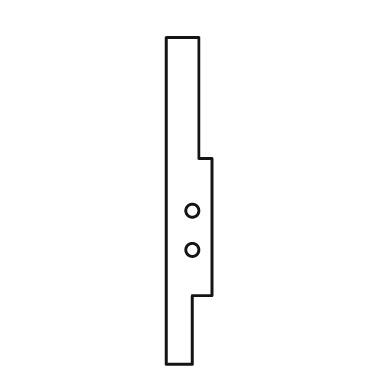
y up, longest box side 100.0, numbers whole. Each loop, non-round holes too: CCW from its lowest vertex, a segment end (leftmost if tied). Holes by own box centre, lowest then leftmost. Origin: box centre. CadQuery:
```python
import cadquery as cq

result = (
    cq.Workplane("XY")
    .moveTo(-7.0, -50.0)
    .lineTo(1.0, -50.0)
    .lineTo(1.0, -29.0)
    .lineTo(7.0, -29.0)
    .lineTo(7.0, 13.0)
    .lineTo(3.0, 13.0)
    .lineTo(3.0, 50.0)
    .lineTo(-7.0, 50.0)
    .close()
    .moveTo(1.0, -15.0)
    .circle(2.0)
    .moveTo(1.0, -3.0)
    .circle(2.0)
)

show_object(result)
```